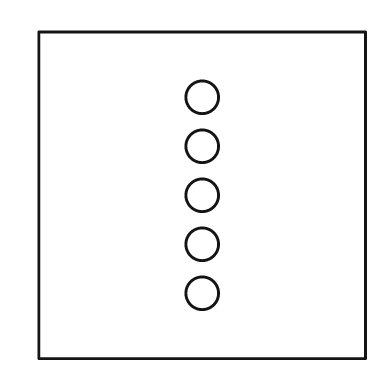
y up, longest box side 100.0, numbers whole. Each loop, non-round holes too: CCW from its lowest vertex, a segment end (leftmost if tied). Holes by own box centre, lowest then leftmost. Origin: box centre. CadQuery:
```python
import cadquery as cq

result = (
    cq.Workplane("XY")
    .moveTo(-50.0, -50.0)
    .lineTo(50.0, -50.0)
    .lineTo(50.0, 50.0)
    .lineTo(-50.0, 50.0)
    .close()
    .moveTo(0.0, -30.0)
    .circle(5.0)
    .moveTo(0.0, -15.0)
    .circle(5.0)
    .moveTo(0.0, 0.0)
    .circle(5.0)
    .moveTo(0.0, 15.0)
    .circle(5.0)
    .moveTo(0.0, 30.0)
    .circle(5.0)
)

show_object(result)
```